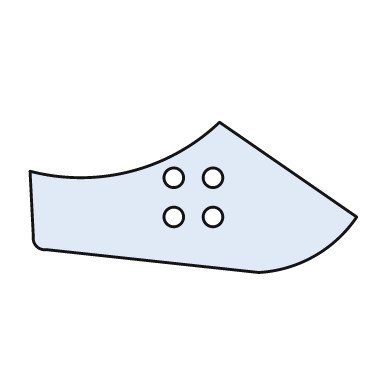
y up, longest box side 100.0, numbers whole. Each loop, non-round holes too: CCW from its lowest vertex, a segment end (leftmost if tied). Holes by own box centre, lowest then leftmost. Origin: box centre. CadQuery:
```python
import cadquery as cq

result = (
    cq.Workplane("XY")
    .moveTo(20.0, -23.0)
    .threePointArc((37.0, -18.0), (50.0, -6.0))
    .lineTo(8.0, 23.0)
    .threePointArc((-19.0, 8.0), (-50.0, 8.0))
    .lineTo(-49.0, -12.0)
    .threePointArc((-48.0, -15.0), (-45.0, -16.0))
    .close()
    .moveTo(-6.0, -6.0)
    .circle(3.0)
    .moveTo(6.0, -6.0)
    .circle(3.0)
    .moveTo(-6.0, 6.0)
    .circle(3.0)
    .moveTo(6.0, 6.0)
    .circle(3.0)
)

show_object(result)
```